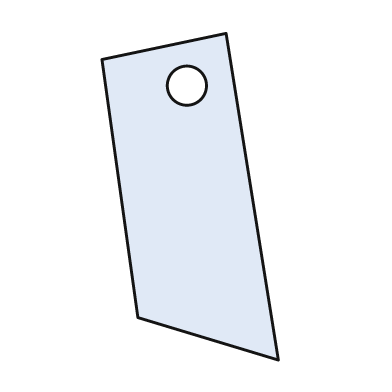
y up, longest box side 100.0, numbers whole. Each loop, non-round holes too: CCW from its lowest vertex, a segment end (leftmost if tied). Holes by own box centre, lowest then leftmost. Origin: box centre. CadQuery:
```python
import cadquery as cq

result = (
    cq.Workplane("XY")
    .moveTo(27.0, -50.0)
    .lineTo(11.0, 50.0)
    .lineTo(-27.0, 42.0)
    .lineTo(-16.0, -37.0)
    .close()
    .moveTo(-1.0, 34.0)
    .circle(6.0)
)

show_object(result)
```